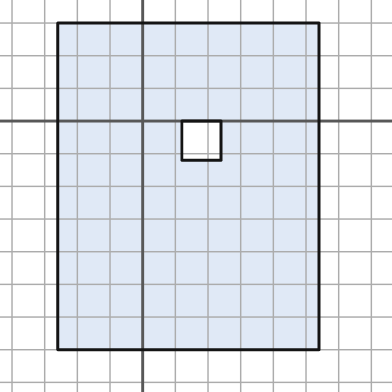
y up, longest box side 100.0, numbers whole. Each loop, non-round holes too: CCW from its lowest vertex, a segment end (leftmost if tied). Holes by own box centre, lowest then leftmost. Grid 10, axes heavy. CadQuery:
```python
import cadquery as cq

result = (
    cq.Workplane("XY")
    .moveTo(-26.0, -70.0)
    .lineTo(54.0, -70.0)
    .lineTo(54.0, 30.0)
    .lineTo(-26.0, 30.0)
    .close()
    .moveTo(12.0, -12.0)
    .lineTo(24.0, -12.0)
    .lineTo(24.0, 0.0)
    .lineTo(12.0, 0.0)
    .close()
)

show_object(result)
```